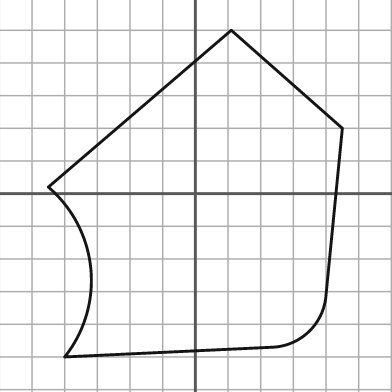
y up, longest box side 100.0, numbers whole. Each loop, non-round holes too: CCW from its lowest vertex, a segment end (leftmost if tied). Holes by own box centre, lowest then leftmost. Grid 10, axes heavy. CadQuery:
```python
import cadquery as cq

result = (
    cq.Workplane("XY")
    .moveTo(-40.0, -50.0)
    .lineTo(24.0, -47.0)
    .threePointArc((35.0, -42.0), (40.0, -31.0))
    .lineTo(45.0, 20.0)
    .lineTo(11.0, 50.0)
    .lineTo(-45.0, 2.0)
    .threePointArc((-32.0, -23.0), (-40.0, -50.0))
    .close()
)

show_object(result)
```